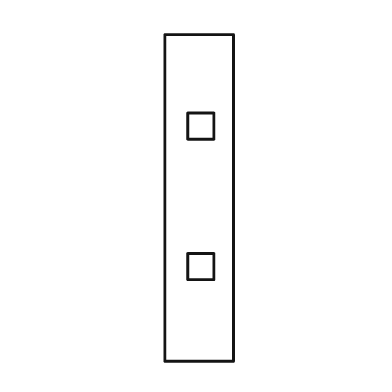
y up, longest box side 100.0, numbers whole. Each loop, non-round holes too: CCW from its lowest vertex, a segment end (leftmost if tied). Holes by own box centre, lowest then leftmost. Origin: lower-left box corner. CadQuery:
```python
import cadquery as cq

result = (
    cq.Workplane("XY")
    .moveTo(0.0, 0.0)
    .lineTo(21.0, 0.0)
    .lineTo(21.0, 100.0)
    .lineTo(0.0, 100.0)
    .close()
    .moveTo(7.0, 25.0)
    .lineTo(15.0, 25.0)
    .lineTo(15.0, 33.0)
    .lineTo(7.0, 33.0)
    .close()
    .moveTo(7.0, 68.0)
    .lineTo(15.0, 68.0)
    .lineTo(15.0, 76.0)
    .lineTo(7.0, 76.0)
    .close()
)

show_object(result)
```